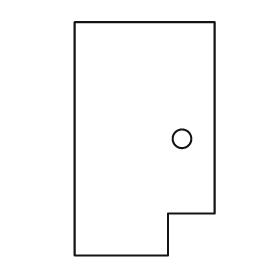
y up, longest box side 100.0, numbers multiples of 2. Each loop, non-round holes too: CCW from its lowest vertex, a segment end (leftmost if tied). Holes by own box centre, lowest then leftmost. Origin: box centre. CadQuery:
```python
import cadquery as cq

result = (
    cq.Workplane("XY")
    .moveTo(-30.0, -50.0)
    .lineTo(10.0, -50.0)
    .lineTo(10.0, -32.0)
    .lineTo(30.0, -32.0)
    .lineTo(30.0, 50.0)
    .lineTo(-30.0, 50.0)
    .close()
    .moveTo(16.0, 0.0)
    .circle(4.0)
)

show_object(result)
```